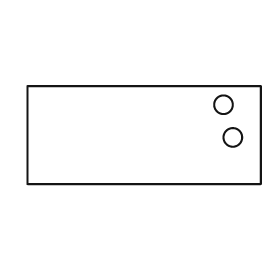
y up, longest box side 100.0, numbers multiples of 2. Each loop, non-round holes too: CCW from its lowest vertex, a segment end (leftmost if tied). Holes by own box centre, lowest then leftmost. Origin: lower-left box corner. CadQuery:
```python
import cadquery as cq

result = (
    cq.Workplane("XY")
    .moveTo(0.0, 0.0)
    .lineTo(100.0, 0.0)
    .lineTo(100.0, 42.0)
    .lineTo(0.0, 42.0)
    .close()
    .moveTo(88.0, 20.0)
    .circle(4.0)
    .moveTo(84.0, 34.0)
    .circle(4.0)
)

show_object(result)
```